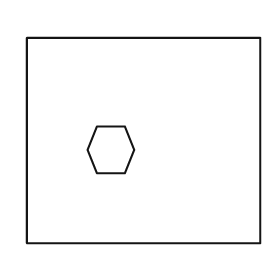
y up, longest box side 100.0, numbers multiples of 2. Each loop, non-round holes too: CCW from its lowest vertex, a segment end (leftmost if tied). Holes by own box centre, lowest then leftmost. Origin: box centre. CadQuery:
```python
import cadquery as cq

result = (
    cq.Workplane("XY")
    .moveTo(-50.0, -44.0)
    .lineTo(50.0, -44.0)
    .lineTo(50.0, 44.0)
    .lineTo(-50.0, 44.0)
    .close()
    .moveTo(-20.0, -14.0)
    .lineTo(-8.0, -14.0)
    .lineTo(-4.0, -4.0)
    .lineTo(-8.0, 6.0)
    .lineTo(-20.0, 6.0)
    .lineTo(-24.0, -4.0)
    .close()
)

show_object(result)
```